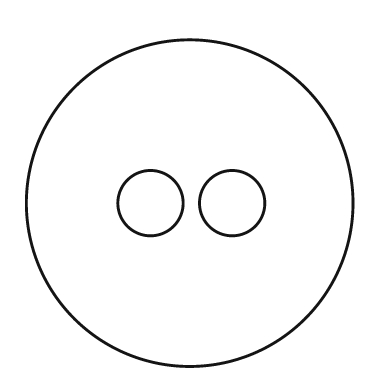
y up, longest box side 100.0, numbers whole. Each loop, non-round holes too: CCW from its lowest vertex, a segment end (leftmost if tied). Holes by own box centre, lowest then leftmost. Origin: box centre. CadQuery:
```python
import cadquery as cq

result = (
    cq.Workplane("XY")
    .moveTo(0.0, 0.0)
    .circle(50.0)
    .moveTo(-12.0, 0.0)
    .circle(10.0)
    .moveTo(13.0, 0.0)
    .circle(10.0)
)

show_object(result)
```